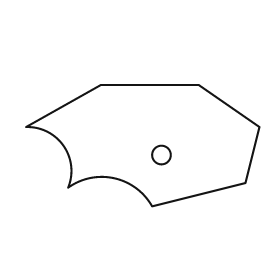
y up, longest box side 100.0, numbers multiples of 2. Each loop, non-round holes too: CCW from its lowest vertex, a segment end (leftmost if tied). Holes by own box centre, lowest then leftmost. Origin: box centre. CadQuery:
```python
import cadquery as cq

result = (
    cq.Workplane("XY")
    .moveTo(4.0, -26.0)
    .lineTo(44.0, -16.0)
    .lineTo(50.0, 8.0)
    .lineTo(24.0, 26.0)
    .lineTo(-18.0, 26.0)
    .lineTo(-50.0, 8.0)
    .threePointArc((-34.0, 0.0), (-32.0, -18.0))
    .threePointArc((-12.0, -14.0), (4.0, -26.0))
    .close()
    .moveTo(8.0, -4.0)
    .circle(4.0)
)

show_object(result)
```